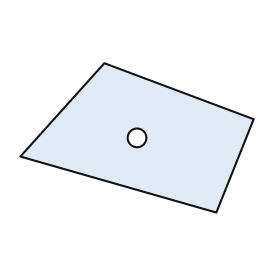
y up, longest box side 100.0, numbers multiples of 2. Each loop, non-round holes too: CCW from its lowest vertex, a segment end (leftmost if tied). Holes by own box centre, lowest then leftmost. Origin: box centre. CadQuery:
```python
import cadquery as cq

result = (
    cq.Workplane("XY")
    .moveTo(34.0, -32.0)
    .lineTo(50.0, 8.0)
    .lineTo(-14.0, 32.0)
    .lineTo(-50.0, -8.0)
    .close()
    .moveTo(0.0, 0.0)
    .circle(4.0)
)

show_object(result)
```